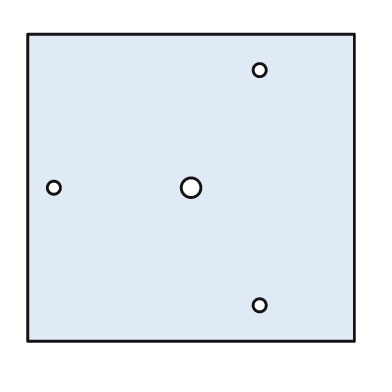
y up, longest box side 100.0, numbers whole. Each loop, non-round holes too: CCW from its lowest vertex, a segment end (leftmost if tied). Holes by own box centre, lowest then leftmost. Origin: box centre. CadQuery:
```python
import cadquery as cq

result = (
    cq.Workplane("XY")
    .moveTo(-50.0, -47.0)
    .lineTo(50.0, -47.0)
    .lineTo(50.0, 47.0)
    .lineTo(-50.0, 47.0)
    .close()
    .moveTo(21.0, -36.0)
    .circle(2.0)
    .moveTo(-42.0, 0.0)
    .circle(2.0)
    .moveTo(0.0, 0.0)
    .circle(3.0)
    .moveTo(21.0, 36.0)
    .circle(2.0)
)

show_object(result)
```